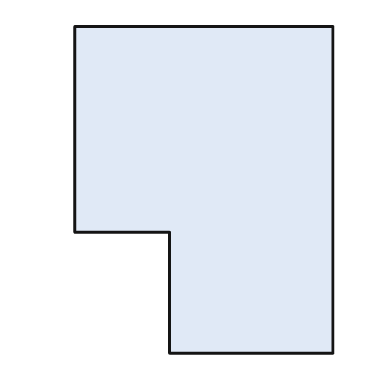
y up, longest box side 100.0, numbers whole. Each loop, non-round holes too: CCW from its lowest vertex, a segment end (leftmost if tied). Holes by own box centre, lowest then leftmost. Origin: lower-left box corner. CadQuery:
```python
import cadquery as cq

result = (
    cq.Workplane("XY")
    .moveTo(29.0, 0.0)
    .lineTo(79.0, 0.0)
    .lineTo(79.0, 100.0)
    .lineTo(0.0, 100.0)
    .lineTo(0.0, 37.0)
    .lineTo(29.0, 37.0)
    .close()
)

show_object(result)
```